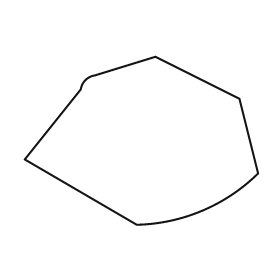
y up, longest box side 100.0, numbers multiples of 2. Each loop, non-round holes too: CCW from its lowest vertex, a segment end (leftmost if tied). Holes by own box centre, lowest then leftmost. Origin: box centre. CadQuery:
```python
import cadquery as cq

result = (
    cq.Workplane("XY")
    .moveTo(-2.0, -36.0)
    .threePointArc((26.0, -30.0), (50.0, -14.0))
    .lineTo(42.0, 18.0)
    .lineTo(6.0, 36.0)
    .lineTo(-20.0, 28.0)
    .threePointArc((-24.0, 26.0), (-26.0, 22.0))
    .lineTo(-50.0, -8.0)
    .close()
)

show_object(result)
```